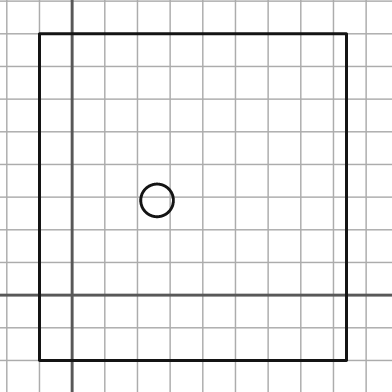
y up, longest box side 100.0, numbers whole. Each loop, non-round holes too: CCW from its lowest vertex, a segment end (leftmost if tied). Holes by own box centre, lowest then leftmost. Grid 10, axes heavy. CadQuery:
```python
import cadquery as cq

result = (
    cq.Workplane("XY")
    .moveTo(-10.0, -20.0)
    .lineTo(84.0, -20.0)
    .lineTo(84.0, 80.0)
    .lineTo(-10.0, 80.0)
    .close()
    .moveTo(26.0, 29.0)
    .circle(5.0)
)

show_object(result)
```